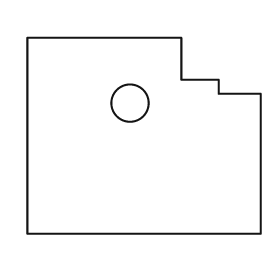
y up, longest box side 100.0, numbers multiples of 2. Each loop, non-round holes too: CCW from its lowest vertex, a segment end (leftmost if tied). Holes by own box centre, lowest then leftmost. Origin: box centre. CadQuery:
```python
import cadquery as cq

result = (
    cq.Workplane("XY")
    .moveTo(-50.0, -42.0)
    .lineTo(50.0, -42.0)
    .lineTo(50.0, 18.0)
    .lineTo(32.0, 18.0)
    .lineTo(32.0, 24.0)
    .lineTo(16.0, 24.0)
    .lineTo(16.0, 42.0)
    .lineTo(-50.0, 42.0)
    .close()
    .moveTo(-6.0, 14.0)
    .circle(8.0)
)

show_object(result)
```